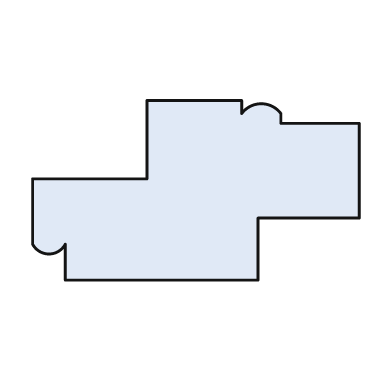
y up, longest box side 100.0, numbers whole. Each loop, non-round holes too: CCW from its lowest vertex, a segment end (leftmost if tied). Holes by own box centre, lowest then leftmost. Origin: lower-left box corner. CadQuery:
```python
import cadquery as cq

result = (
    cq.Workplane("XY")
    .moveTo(10.0, 0.0)
    .lineTo(69.0, 0.0)
    .lineTo(69.0, 19.0)
    .lineTo(100.0, 19.0)
    .lineTo(100.0, 48.0)
    .lineTo(76.0, 48.0)
    .lineTo(76.0, 51.0)
    .threePointArc((70.0, 54.0), (64.0, 51.0))
    .lineTo(64.0, 55.0)
    .lineTo(35.0, 55.0)
    .lineTo(35.0, 31.0)
    .lineTo(0.0, 31.0)
    .lineTo(0.0, 11.0)
    .threePointArc((5.0, 8.0), (10.0, 11.0))
    .close()
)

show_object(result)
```